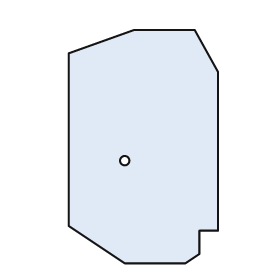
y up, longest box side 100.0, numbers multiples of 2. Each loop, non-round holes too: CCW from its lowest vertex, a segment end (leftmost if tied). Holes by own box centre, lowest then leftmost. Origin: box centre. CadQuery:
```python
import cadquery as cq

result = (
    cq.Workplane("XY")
    .moveTo(-8.0, -50.0)
    .lineTo(18.0, -50.0)
    .lineTo(24.0, -46.0)
    .lineTo(24.0, -36.0)
    .lineTo(32.0, -36.0)
    .lineTo(32.0, 32.0)
    .lineTo(22.0, 50.0)
    .lineTo(-4.0, 50.0)
    .lineTo(-32.0, 40.0)
    .lineTo(-32.0, -34.0)
    .close()
    .moveTo(-8.0, -6.0)
    .circle(2.0)
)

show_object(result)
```